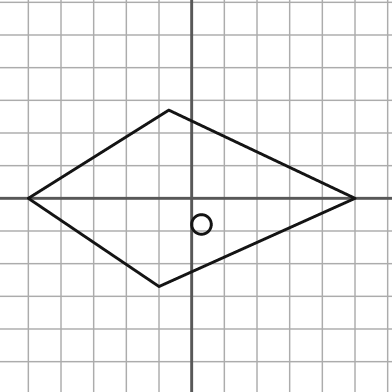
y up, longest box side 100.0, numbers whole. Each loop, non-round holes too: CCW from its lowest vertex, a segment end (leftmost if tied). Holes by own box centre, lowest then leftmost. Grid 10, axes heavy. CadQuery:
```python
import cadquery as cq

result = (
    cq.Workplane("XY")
    .moveTo(-10.0, -27.0)
    .lineTo(50.0, 0.0)
    .lineTo(-7.0, 27.0)
    .lineTo(-50.0, 0.0)
    .close()
    .moveTo(3.0, -8.0)
    .circle(3.0)
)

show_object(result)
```